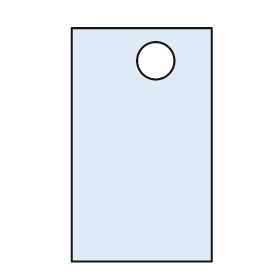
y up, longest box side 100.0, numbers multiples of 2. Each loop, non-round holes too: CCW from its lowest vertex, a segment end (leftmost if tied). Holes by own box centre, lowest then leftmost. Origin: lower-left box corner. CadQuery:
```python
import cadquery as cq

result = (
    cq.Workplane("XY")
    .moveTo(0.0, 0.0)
    .lineTo(60.0, 0.0)
    .lineTo(60.0, 100.0)
    .lineTo(0.0, 100.0)
    .close()
    .moveTo(36.0, 86.0)
    .circle(8.0)
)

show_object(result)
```